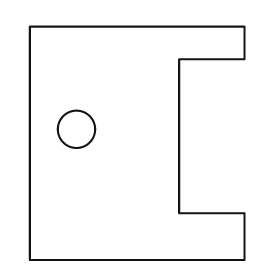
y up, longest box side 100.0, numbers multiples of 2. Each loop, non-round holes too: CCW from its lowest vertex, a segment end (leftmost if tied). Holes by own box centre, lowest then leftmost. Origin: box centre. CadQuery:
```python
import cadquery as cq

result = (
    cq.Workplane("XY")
    .moveTo(-46.0, -50.0)
    .lineTo(46.0, -50.0)
    .lineTo(46.0, -30.0)
    .lineTo(18.0, -30.0)
    .lineTo(18.0, 36.0)
    .lineTo(46.0, 36.0)
    .lineTo(46.0, 50.0)
    .lineTo(-46.0, 50.0)
    .close()
    .moveTo(-26.0, 6.0)
    .circle(8.0)
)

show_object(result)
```